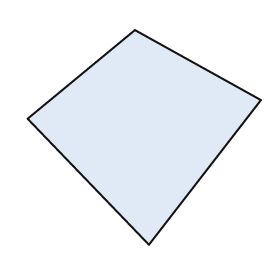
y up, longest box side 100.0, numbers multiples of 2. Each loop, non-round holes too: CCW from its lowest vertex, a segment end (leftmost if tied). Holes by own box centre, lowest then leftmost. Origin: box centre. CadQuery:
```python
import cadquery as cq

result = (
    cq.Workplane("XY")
    .moveTo(2.0, -46.0)
    .lineTo(50.0, 16.0)
    .lineTo(-4.0, 46.0)
    .lineTo(-50.0, 8.0)
    .close()
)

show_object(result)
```